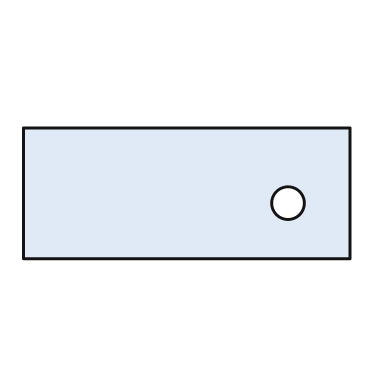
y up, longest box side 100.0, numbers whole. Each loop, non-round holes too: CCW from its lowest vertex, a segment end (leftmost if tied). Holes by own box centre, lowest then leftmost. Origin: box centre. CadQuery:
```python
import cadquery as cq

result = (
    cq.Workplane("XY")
    .moveTo(-50.0, -20.0)
    .lineTo(50.0, -20.0)
    .lineTo(50.0, 20.0)
    .lineTo(-50.0, 20.0)
    .close()
    .moveTo(31.0, -3.0)
    .circle(5.0)
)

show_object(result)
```